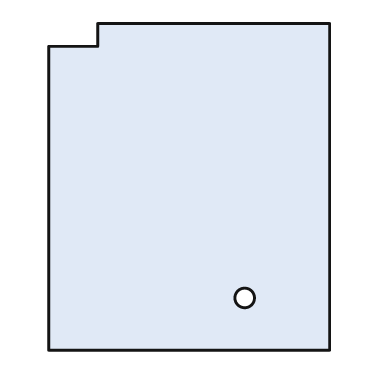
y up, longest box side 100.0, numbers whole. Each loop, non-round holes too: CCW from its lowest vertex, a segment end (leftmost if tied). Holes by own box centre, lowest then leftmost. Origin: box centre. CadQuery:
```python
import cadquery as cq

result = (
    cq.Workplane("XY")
    .moveTo(-43.0, -50.0)
    .lineTo(43.0, -50.0)
    .lineTo(43.0, 50.0)
    .lineTo(-28.0, 50.0)
    .lineTo(-28.0, 43.0)
    .lineTo(-43.0, 43.0)
    .close()
    .moveTo(17.0, -34.0)
    .circle(3.0)
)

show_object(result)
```